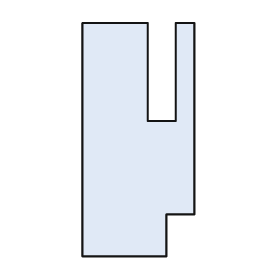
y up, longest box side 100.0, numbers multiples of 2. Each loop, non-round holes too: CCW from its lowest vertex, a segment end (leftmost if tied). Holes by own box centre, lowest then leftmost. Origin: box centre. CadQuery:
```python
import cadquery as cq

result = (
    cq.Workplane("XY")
    .moveTo(-24.0, -50.0)
    .lineTo(12.0, -50.0)
    .lineTo(12.0, -32.0)
    .lineTo(24.0, -32.0)
    .lineTo(24.0, 50.0)
    .lineTo(16.0, 50.0)
    .lineTo(16.0, 8.0)
    .lineTo(4.0, 8.0)
    .lineTo(4.0, 50.0)
    .lineTo(-24.0, 50.0)
    .close()
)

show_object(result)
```